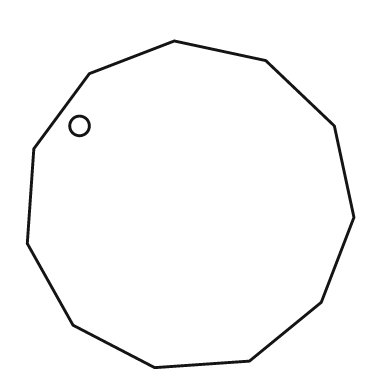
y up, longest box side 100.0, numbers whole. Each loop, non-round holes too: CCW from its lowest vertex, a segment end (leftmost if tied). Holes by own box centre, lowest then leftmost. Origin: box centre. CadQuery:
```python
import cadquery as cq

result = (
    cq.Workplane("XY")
    .moveTo(-11.0, -50.0)
    .lineTo(18.0, -48.0)
    .lineTo(40.0, -30.0)
    .lineTo(50.0, -4.0)
    .lineTo(44.0, 24.0)
    .lineTo(23.0, 44.0)
    .lineTo(-5.0, 50.0)
    .lineTo(-31.0, 40.0)
    .lineTo(-48.0, 17.0)
    .lineTo(-50.0, -12.0)
    .lineTo(-36.0, -37.0)
    .close()
    .moveTo(-34.0, 24.0)
    .circle(3.0)
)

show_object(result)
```